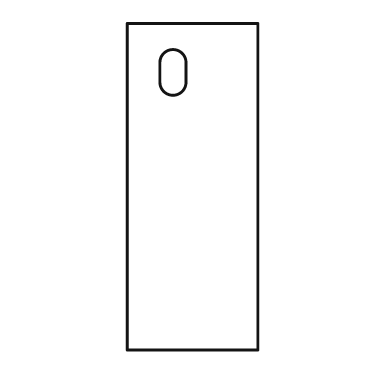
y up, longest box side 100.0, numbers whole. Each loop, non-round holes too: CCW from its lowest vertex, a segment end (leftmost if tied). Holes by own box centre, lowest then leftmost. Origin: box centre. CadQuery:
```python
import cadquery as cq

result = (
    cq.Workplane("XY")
    .moveTo(-20.0, -50.0)
    .lineTo(20.0, -50.0)
    .lineTo(20.0, 50.0)
    .lineTo(-20.0, 50.0)
    .close()
    .moveTo(-10.0, 32.0)
    .threePointArc((-6.0, 28.0), (-2.0, 32.0))
    .lineTo(-2.0, 38.0)
    .threePointArc((-6.0, 42.0), (-10.0, 38.0))
    .close()
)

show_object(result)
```